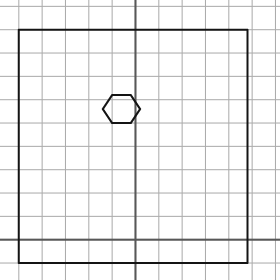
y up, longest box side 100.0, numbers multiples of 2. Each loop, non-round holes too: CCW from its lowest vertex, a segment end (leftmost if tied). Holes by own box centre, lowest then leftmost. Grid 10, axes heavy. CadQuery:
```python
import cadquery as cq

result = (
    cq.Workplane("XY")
    .moveTo(-50.0, -10.0)
    .lineTo(48.0, -10.0)
    .lineTo(48.0, 90.0)
    .lineTo(-50.0, 90.0)
    .close()
    .moveTo(-10.0, 50.0)
    .lineTo(-2.0, 50.0)
    .lineTo(2.0, 56.0)
    .lineTo(-2.0, 62.0)
    .lineTo(-10.0, 62.0)
    .lineTo(-14.0, 56.0)
    .close()
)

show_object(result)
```